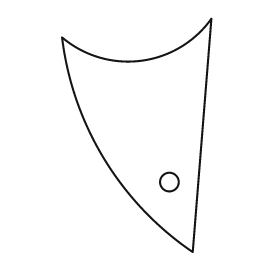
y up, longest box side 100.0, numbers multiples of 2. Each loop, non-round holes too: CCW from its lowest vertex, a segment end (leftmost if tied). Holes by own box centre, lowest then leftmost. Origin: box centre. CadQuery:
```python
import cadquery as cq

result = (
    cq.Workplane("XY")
    .moveTo(24.0, -50.0)
    .lineTo(32.0, 50.0)
    .threePointArc((2.0, 32.0), (-32.0, 42.0))
    .threePointArc((-14.0, -10.0), (24.0, -50.0))
    .close()
    .moveTo(14.0, -20.0)
    .circle(4.0)
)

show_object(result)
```